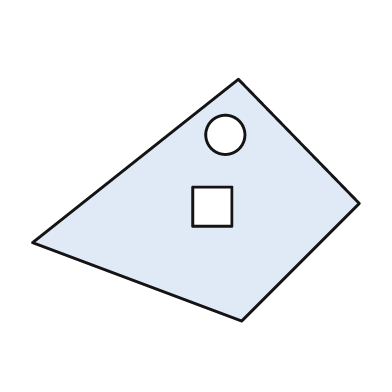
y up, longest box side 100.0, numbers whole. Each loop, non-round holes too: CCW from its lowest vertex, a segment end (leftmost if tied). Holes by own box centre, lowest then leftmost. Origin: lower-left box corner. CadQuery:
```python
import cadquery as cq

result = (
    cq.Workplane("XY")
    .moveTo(64.0, 0.0)
    .lineTo(100.0, 36.0)
    .lineTo(63.0, 74.0)
    .lineTo(0.0, 24.0)
    .close()
    .moveTo(49.0, 29.0)
    .lineTo(61.0, 29.0)
    .lineTo(61.0, 41.0)
    .lineTo(49.0, 41.0)
    .close()
    .moveTo(59.0, 57.0)
    .circle(6.0)
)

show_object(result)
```